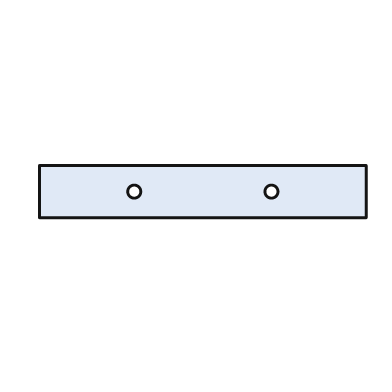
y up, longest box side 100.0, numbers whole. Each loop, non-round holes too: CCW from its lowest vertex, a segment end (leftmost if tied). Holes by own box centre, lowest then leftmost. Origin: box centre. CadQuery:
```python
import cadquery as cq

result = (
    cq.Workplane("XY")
    .moveTo(-50.0, -8.0)
    .lineTo(50.0, -8.0)
    .lineTo(50.0, 8.0)
    .lineTo(-50.0, 8.0)
    .close()
    .moveTo(-21.0, 0.0)
    .circle(2.0)
    .moveTo(21.0, 0.0)
    .circle(2.0)
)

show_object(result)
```